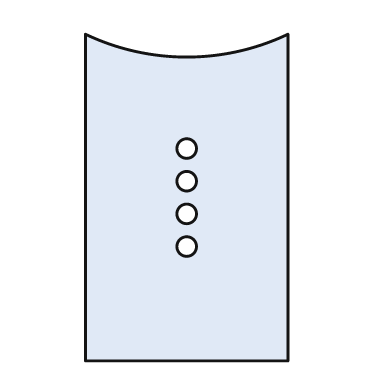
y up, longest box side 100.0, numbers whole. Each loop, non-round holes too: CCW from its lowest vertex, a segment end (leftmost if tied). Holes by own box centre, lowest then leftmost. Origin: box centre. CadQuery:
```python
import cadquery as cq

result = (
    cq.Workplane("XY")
    .moveTo(-31.0, -50.0)
    .lineTo(31.0, -50.0)
    .lineTo(31.0, 50.0)
    .threePointArc((0.0, 43.0), (-31.0, 50.0))
    .close()
    .moveTo(0.0, -15.0)
    .circle(3.0)
    .moveTo(0.0, -5.0)
    .circle(3.0)
    .moveTo(0.0, 5.0)
    .circle(3.0)
    .moveTo(0.0, 15.0)
    .circle(3.0)
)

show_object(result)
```